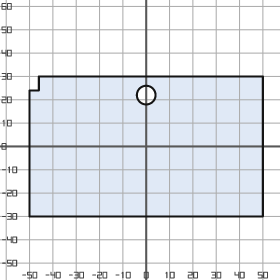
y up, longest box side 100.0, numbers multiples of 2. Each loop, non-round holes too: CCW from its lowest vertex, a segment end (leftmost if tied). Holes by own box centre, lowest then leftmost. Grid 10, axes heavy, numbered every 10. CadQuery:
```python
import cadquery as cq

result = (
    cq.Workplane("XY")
    .moveTo(-50.0, -30.0)
    .lineTo(50.0, -30.0)
    .lineTo(50.0, 30.0)
    .lineTo(-46.0, 30.0)
    .lineTo(-46.0, 24.0)
    .lineTo(-50.0, 24.0)
    .close()
    .moveTo(0.0, 22.0)
    .circle(4.0)
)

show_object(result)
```